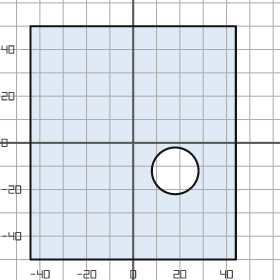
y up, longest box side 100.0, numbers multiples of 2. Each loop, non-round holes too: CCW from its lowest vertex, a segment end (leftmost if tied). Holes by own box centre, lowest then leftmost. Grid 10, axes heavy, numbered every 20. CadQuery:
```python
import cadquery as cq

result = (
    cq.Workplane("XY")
    .moveTo(-44.0, -50.0)
    .lineTo(44.0, -50.0)
    .lineTo(44.0, 50.0)
    .lineTo(-44.0, 50.0)
    .close()
    .moveTo(18.0, -12.0)
    .circle(10.0)
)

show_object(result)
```